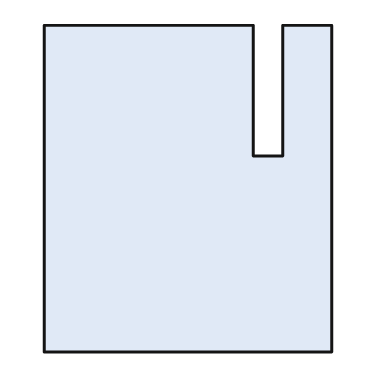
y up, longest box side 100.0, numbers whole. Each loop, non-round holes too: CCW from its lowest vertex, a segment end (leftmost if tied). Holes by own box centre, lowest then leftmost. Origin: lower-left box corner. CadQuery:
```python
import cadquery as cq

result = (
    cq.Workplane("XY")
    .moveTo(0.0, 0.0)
    .lineTo(88.0, 0.0)
    .lineTo(88.0, 100.0)
    .lineTo(73.0, 100.0)
    .lineTo(73.0, 60.0)
    .lineTo(64.0, 60.0)
    .lineTo(64.0, 100.0)
    .lineTo(0.0, 100.0)
    .close()
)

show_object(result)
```